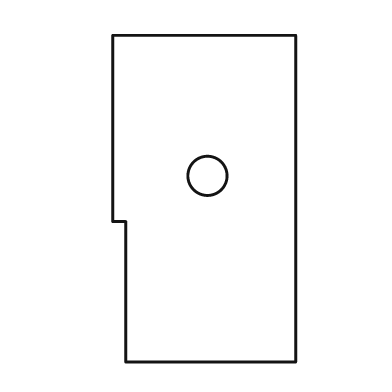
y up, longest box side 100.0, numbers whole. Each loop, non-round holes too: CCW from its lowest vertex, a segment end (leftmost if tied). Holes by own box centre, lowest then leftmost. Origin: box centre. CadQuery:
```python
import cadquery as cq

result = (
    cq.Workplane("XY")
    .moveTo(-24.0, -50.0)
    .lineTo(28.0, -50.0)
    .lineTo(28.0, 50.0)
    .lineTo(-28.0, 50.0)
    .lineTo(-28.0, -7.0)
    .lineTo(-24.0, -7.0)
    .close()
    .moveTo(1.0, 7.0)
    .circle(6.0)
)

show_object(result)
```